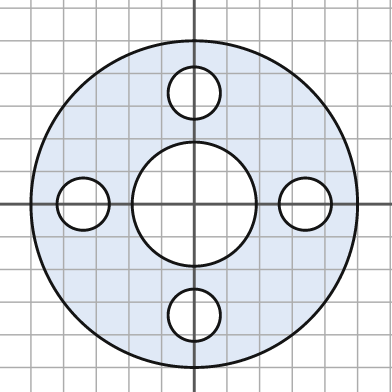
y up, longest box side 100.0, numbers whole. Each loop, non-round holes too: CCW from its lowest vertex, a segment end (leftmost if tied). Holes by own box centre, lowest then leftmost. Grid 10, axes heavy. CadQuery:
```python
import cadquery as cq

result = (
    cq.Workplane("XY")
    .moveTo(0.0, 0.0)
    .circle(50.0)
    .moveTo(0.0, -34.0)
    .circle(8.0)
    .moveTo(-34.0, 0.0)
    .circle(8.0)
    .moveTo(0.0, 0.0)
    .circle(19.0)
    .moveTo(34.0, 0.0)
    .circle(8.0)
    .moveTo(0.0, 34.0)
    .circle(8.0)
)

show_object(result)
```